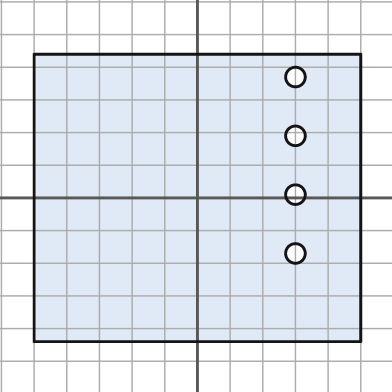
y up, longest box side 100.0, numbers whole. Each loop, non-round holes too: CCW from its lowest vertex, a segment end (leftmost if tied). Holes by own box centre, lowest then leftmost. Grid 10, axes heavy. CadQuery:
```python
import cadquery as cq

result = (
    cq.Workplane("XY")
    .moveTo(-50.0, -44.0)
    .lineTo(50.0, -44.0)
    .lineTo(50.0, 44.0)
    .lineTo(-50.0, 44.0)
    .close()
    .moveTo(30.0, -17.0)
    .circle(3.0)
    .moveTo(30.0, 1.0)
    .circle(3.0)
    .moveTo(30.0, 19.0)
    .circle(3.0)
    .moveTo(30.0, 37.0)
    .circle(3.0)
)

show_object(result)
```